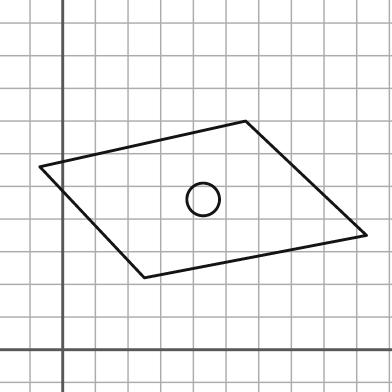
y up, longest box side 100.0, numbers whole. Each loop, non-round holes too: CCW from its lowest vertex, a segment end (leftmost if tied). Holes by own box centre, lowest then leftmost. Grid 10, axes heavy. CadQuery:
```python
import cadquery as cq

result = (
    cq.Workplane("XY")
    .moveTo(25.0, 22.0)
    .lineTo(93.0, 35.0)
    .lineTo(56.0, 70.0)
    .lineTo(-7.0, 56.0)
    .close()
    .moveTo(43.0, 46.0)
    .circle(5.0)
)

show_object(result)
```